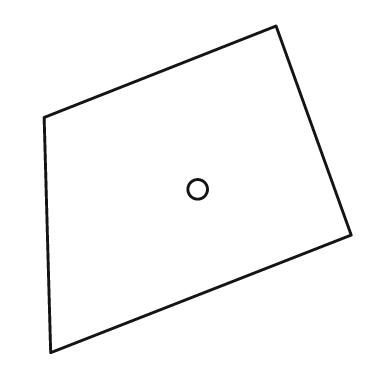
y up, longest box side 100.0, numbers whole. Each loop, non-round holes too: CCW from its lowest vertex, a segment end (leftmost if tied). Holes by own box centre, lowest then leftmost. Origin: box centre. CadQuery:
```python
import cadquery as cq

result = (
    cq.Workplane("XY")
    .moveTo(-45.0, -50.0)
    .lineTo(47.0, -14.0)
    .lineTo(24.0, 50.0)
    .lineTo(-47.0, 22.0)
    .close()
    .moveTo(0.0, 0.0)
    .circle(3.0)
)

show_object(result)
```